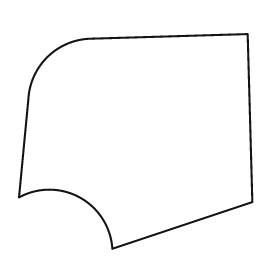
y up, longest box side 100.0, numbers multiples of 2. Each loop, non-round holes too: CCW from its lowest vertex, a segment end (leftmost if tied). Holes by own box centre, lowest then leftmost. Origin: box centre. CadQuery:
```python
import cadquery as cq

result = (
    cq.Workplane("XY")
    .moveTo(-10.0, -46.0)
    .lineTo(50.0, -26.0)
    .lineTo(48.0, 46.0)
    .lineTo(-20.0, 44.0)
    .threePointArc((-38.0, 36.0), (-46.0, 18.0))
    .lineTo(-50.0, -24.0)
    .threePointArc((-24.0, -24.0), (-10.0, -46.0))
    .close()
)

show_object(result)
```